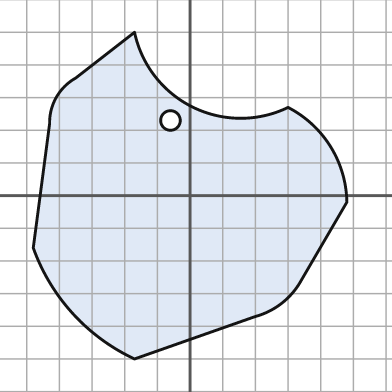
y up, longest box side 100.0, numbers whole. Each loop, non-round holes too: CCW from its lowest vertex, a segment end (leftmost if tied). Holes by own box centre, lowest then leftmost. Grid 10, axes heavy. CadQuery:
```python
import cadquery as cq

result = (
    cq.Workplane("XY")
    .moveTo(-17.0, -50.0)
    .lineTo(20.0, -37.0)
    .threePointArc((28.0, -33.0), (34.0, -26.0))
    .lineTo(48.0, -2.0)
    .threePointArc((43.0, 15.0), (30.0, 27.0))
    .threePointArc((1.0, 27.0), (-17.0, 50.0))
    .lineTo(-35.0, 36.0)
    .threePointArc((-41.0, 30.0), (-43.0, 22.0))
    .lineTo(-48.0, -16.0)
    .threePointArc((-36.0, -36.0), (-17.0, -50.0))
    .close()
    .moveTo(-6.0, 23.0)
    .circle(3.0)
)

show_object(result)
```